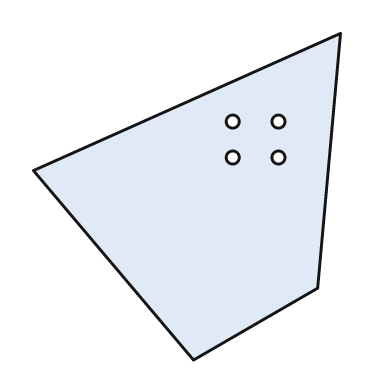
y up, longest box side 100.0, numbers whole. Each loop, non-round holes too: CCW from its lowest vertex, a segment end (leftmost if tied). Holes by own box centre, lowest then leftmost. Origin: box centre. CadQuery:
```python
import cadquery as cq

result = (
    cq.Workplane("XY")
    .moveTo(2.0, -50.0)
    .lineTo(40.0, -28.0)
    .lineTo(47.0, 50.0)
    .lineTo(-47.0, 8.0)
    .close()
    .moveTo(14.0, 12.0)
    .circle(2.0)
    .moveTo(28.0, 12.0)
    .circle(2.0)
    .moveTo(14.0, 23.0)
    .circle(2.0)
    .moveTo(28.0, 23.0)
    .circle(2.0)
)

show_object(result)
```